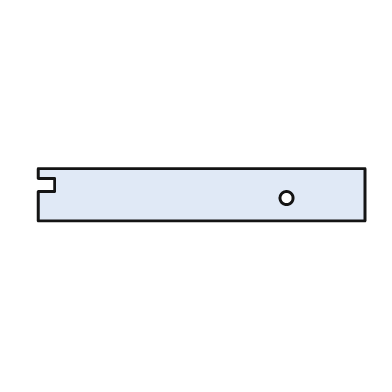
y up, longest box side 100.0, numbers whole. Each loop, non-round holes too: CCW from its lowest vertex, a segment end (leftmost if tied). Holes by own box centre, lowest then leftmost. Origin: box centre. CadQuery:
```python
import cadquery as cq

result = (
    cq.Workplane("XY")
    .moveTo(-50.0, -8.0)
    .lineTo(50.0, -8.0)
    .lineTo(50.0, 8.0)
    .lineTo(-50.0, 8.0)
    .lineTo(-50.0, 5.0)
    .lineTo(-45.0, 5.0)
    .lineTo(-45.0, 1.0)
    .lineTo(-50.0, 1.0)
    .close()
    .moveTo(26.0, -1.0)
    .circle(2.0)
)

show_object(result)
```